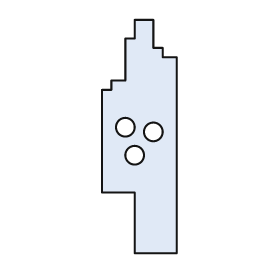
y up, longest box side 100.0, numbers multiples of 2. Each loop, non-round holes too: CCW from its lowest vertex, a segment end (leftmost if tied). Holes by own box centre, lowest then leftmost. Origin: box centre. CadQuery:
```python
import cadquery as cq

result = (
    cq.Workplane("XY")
    .moveTo(-2.0, -50.0)
    .lineTo(16.0, -50.0)
    .lineTo(16.0, 34.0)
    .lineTo(10.0, 34.0)
    .lineTo(10.0, 38.0)
    .lineTo(6.0, 38.0)
    .lineTo(6.0, 50.0)
    .lineTo(-2.0, 50.0)
    .lineTo(-2.0, 42.0)
    .lineTo(-6.0, 42.0)
    .lineTo(-6.0, 24.0)
    .lineTo(-12.0, 24.0)
    .lineTo(-12.0, 20.0)
    .lineTo(-16.0, 20.0)
    .lineTo(-16.0, -24.0)
    .lineTo(-2.0, -24.0)
    .close()
    .moveTo(-2.0, -8.0)
    .circle(4.0)
    .moveTo(6.0, 2.0)
    .circle(4.0)
    .moveTo(-6.0, 4.0)
    .circle(4.0)
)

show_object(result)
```